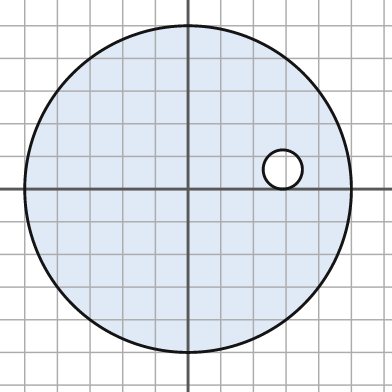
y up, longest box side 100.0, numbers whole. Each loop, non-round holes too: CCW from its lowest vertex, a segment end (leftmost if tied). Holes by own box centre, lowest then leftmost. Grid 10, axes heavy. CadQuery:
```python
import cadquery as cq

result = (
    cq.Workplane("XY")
    .moveTo(0.0, 0.0)
    .circle(50.0)
    .moveTo(29.0, 6.0)
    .circle(6.0)
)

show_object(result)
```